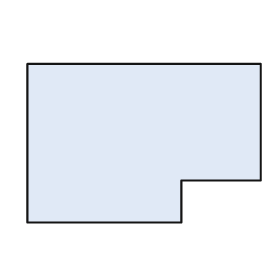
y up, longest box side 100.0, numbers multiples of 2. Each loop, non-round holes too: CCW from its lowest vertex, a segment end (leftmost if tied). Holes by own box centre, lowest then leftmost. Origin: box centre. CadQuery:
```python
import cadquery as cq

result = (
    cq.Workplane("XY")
    .moveTo(-50.0, -34.0)
    .lineTo(16.0, -34.0)
    .lineTo(16.0, -16.0)
    .lineTo(50.0, -16.0)
    .lineTo(50.0, 34.0)
    .lineTo(-50.0, 34.0)
    .close()
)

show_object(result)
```